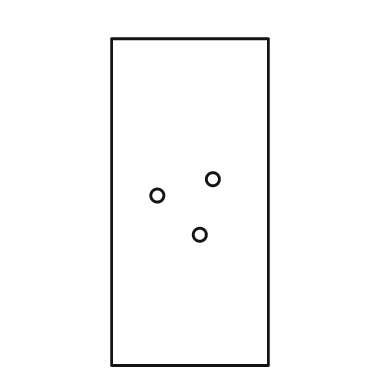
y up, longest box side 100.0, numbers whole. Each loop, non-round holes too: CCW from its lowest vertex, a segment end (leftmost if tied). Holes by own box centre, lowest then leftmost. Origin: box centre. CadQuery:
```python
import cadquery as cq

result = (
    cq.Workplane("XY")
    .moveTo(-24.0, -50.0)
    .lineTo(24.0, -50.0)
    .lineTo(24.0, 50.0)
    .lineTo(-24.0, 50.0)
    .close()
    .moveTo(3.0, -10.0)
    .circle(2.0)
    .moveTo(-10.0, 2.0)
    .circle(2.0)
    .moveTo(7.0, 7.0)
    .circle(2.0)
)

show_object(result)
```